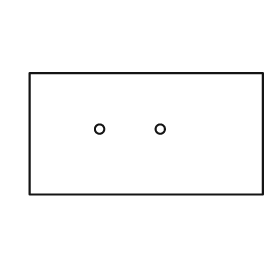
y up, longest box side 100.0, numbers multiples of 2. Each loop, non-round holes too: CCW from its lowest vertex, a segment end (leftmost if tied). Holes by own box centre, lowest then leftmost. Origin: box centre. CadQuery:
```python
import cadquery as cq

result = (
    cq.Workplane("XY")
    .moveTo(-50.0, -26.0)
    .lineTo(50.0, -26.0)
    .lineTo(50.0, 26.0)
    .lineTo(-50.0, 26.0)
    .close()
    .moveTo(-20.0, 2.0)
    .circle(2.0)
    .moveTo(6.0, 2.0)
    .circle(2.0)
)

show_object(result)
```